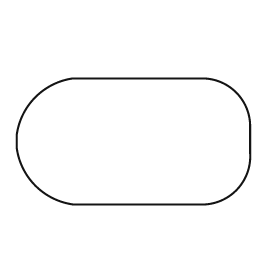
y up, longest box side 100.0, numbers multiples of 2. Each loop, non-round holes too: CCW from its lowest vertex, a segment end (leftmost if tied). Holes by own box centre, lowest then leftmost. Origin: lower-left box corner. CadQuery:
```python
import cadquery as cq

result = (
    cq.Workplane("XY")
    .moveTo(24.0, 0.0)
    .lineTo(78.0, 0.0)
    .threePointArc((94.0, 6.0), (100.0, 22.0))
    .lineTo(100.0, 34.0)
    .threePointArc((94.0, 48.0), (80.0, 54.0))
    .lineTo(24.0, 54.0)
    .threePointArc((8.0, 46.0), (0.0, 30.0))
    .lineTo(0.0, 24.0)
    .threePointArc((8.0, 8.0), (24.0, 0.0))
    .close()
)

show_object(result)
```